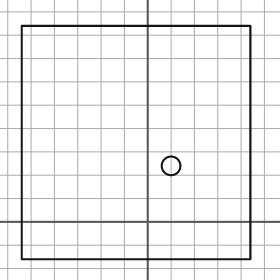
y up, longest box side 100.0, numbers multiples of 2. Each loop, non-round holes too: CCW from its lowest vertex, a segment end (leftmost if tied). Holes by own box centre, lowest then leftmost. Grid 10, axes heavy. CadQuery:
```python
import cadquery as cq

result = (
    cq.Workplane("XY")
    .moveTo(-54.0, -16.0)
    .lineTo(44.0, -16.0)
    .lineTo(44.0, 84.0)
    .lineTo(-54.0, 84.0)
    .close()
    .moveTo(10.0, 24.0)
    .circle(4.0)
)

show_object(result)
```